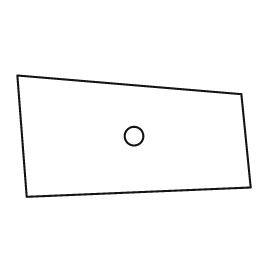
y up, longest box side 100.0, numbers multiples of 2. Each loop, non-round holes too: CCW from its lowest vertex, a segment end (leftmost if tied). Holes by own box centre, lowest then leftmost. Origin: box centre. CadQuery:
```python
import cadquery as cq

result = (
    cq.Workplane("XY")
    .moveTo(-46.0, -26.0)
    .lineTo(50.0, -22.0)
    .lineTo(46.0, 18.0)
    .lineTo(-50.0, 26.0)
    .close()
    .moveTo(0.0, 0.0)
    .circle(4.0)
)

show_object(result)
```